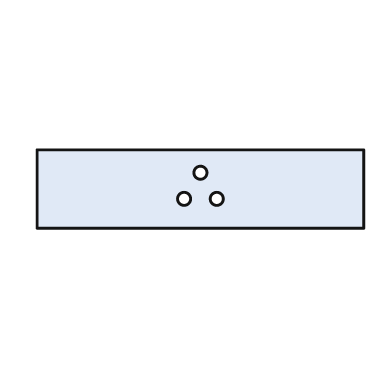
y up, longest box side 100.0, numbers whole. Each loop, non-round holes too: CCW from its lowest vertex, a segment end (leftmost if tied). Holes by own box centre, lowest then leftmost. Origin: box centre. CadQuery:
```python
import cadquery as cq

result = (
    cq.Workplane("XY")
    .moveTo(-50.0, -12.0)
    .lineTo(50.0, -12.0)
    .lineTo(50.0, 12.0)
    .lineTo(-50.0, 12.0)
    .close()
    .moveTo(-5.0, -3.0)
    .circle(2.0)
    .moveTo(5.0, -3.0)
    .circle(2.0)
    .moveTo(0.0, 5.0)
    .circle(2.0)
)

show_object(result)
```